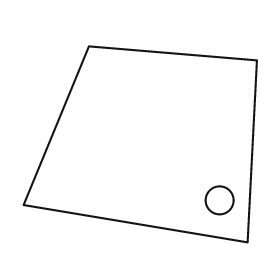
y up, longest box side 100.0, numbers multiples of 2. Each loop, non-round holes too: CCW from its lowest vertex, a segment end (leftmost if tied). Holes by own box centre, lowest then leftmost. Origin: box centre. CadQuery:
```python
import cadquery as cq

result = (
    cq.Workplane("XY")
    .moveTo(46.0, -42.0)
    .lineTo(50.0, 36.0)
    .lineTo(-22.0, 42.0)
    .lineTo(-50.0, -26.0)
    .close()
    .moveTo(34.0, -24.0)
    .circle(6.0)
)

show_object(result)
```